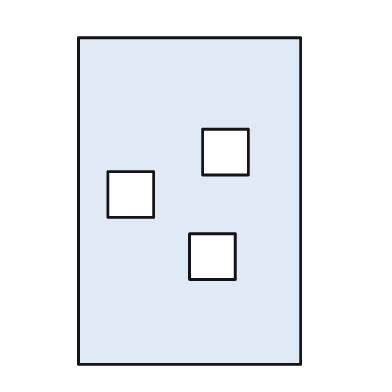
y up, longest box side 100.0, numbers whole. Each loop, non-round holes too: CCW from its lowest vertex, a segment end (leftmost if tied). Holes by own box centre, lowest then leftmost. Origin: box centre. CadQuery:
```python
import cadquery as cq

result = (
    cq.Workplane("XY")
    .moveTo(-34.0, -50.0)
    .lineTo(34.0, -50.0)
    .lineTo(34.0, 50.0)
    .lineTo(-34.0, 50.0)
    .close()
    .moveTo(0.0, -24.0)
    .lineTo(14.0, -24.0)
    .lineTo(14.0, -10.0)
    .lineTo(0.0, -10.0)
    .close()
    .moveTo(-25.0, -5.0)
    .lineTo(-11.0, -5.0)
    .lineTo(-11.0, 9.0)
    .lineTo(-25.0, 9.0)
    .close()
    .moveTo(4.0, 8.0)
    .lineTo(18.0, 8.0)
    .lineTo(18.0, 22.0)
    .lineTo(4.0, 22.0)
    .close()
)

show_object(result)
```